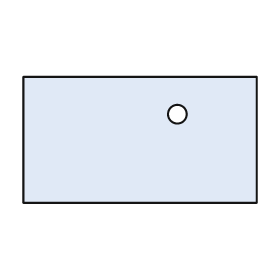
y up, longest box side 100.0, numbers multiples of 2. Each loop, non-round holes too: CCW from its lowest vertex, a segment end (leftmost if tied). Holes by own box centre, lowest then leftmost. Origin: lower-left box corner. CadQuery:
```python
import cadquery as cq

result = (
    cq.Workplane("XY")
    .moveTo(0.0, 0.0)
    .lineTo(100.0, 0.0)
    .lineTo(100.0, 54.0)
    .lineTo(0.0, 54.0)
    .close()
    .moveTo(66.0, 38.0)
    .circle(4.0)
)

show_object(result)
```